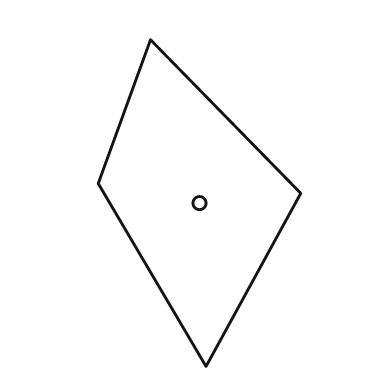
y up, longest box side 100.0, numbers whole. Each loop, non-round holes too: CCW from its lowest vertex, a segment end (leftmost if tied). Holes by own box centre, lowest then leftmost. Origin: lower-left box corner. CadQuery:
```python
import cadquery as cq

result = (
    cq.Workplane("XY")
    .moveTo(33.0, 0.0)
    .lineTo(62.0, 53.0)
    .lineTo(16.0, 100.0)
    .lineTo(0.0, 56.0)
    .close()
    .moveTo(31.0, 50.0)
    .circle(2.0)
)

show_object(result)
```